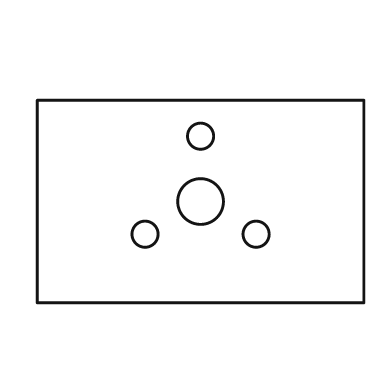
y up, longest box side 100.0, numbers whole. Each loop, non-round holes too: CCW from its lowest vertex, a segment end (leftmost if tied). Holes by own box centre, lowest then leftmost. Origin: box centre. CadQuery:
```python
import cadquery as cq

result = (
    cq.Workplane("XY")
    .moveTo(-50.0, -31.0)
    .lineTo(50.0, -31.0)
    .lineTo(50.0, 31.0)
    .lineTo(-50.0, 31.0)
    .close()
    .moveTo(-17.0, -10.0)
    .circle(4.0)
    .moveTo(17.0, -10.0)
    .circle(4.0)
    .moveTo(0.0, 0.0)
    .circle(7.0)
    .moveTo(0.0, 20.0)
    .circle(4.0)
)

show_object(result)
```